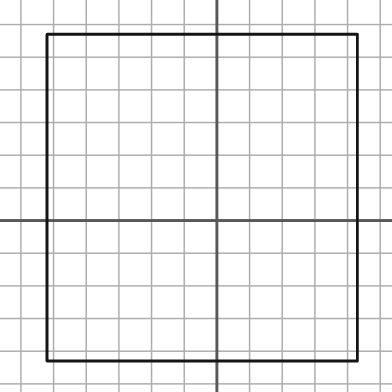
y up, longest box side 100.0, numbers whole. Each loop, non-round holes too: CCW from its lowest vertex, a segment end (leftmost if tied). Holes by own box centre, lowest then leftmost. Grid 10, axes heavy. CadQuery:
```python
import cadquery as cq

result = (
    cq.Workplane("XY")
    .moveTo(-52.0, -43.0)
    .lineTo(43.0, -43.0)
    .lineTo(43.0, 57.0)
    .lineTo(-52.0, 57.0)
    .close()
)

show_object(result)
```